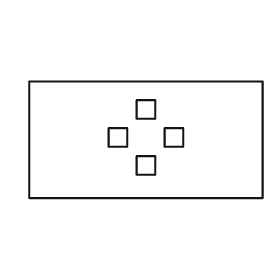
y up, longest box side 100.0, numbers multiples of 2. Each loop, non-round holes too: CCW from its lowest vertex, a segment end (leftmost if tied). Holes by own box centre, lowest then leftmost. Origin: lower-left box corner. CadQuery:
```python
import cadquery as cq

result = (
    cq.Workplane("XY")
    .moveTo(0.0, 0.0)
    .lineTo(100.0, 0.0)
    .lineTo(100.0, 50.0)
    .lineTo(0.0, 50.0)
    .close()
    .moveTo(46.0, 10.0)
    .lineTo(54.0, 10.0)
    .lineTo(54.0, 18.0)
    .lineTo(46.0, 18.0)
    .close()
    .moveTo(34.0, 22.0)
    .lineTo(42.0, 22.0)
    .lineTo(42.0, 30.0)
    .lineTo(34.0, 30.0)
    .close()
    .moveTo(58.0, 22.0)
    .lineTo(66.0, 22.0)
    .lineTo(66.0, 30.0)
    .lineTo(58.0, 30.0)
    .close()
    .moveTo(46.0, 34.0)
    .lineTo(54.0, 34.0)
    .lineTo(54.0, 42.0)
    .lineTo(46.0, 42.0)
    .close()
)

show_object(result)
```